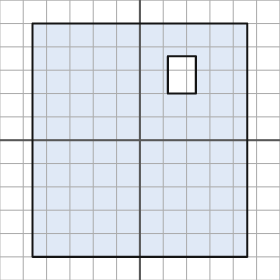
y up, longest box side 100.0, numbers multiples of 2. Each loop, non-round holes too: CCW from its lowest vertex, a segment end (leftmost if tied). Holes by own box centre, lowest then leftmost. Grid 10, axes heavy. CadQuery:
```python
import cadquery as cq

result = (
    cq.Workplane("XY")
    .moveTo(-46.0, -50.0)
    .lineTo(46.0, -50.0)
    .lineTo(46.0, 50.0)
    .lineTo(-46.0, 50.0)
    .close()
    .moveTo(12.0, 20.0)
    .lineTo(24.0, 20.0)
    .lineTo(24.0, 36.0)
    .lineTo(12.0, 36.0)
    .close()
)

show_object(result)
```